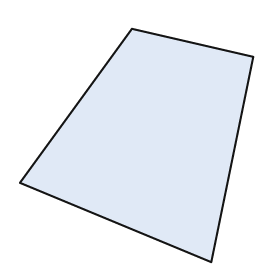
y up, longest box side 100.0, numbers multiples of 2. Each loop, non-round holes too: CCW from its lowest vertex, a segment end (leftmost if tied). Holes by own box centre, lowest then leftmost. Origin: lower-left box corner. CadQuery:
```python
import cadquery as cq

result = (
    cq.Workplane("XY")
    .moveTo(82.0, 0.0)
    .lineTo(100.0, 88.0)
    .lineTo(48.0, 100.0)
    .lineTo(0.0, 34.0)
    .close()
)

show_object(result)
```